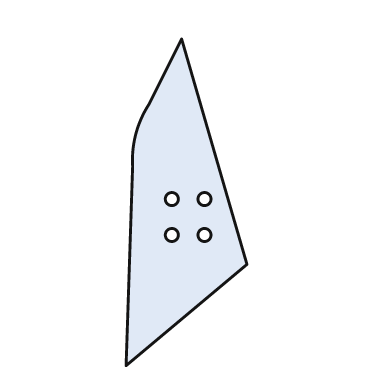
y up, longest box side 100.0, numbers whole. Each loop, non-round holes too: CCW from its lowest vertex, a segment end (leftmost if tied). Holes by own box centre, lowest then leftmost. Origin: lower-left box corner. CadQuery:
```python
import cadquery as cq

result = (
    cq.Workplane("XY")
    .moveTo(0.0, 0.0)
    .lineTo(37.0, 31.0)
    .lineTo(17.0, 100.0)
    .lineTo(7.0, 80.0)
    .threePointArc((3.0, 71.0), (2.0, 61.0))
    .close()
    .moveTo(14.0, 40.0)
    .circle(2.0)
    .moveTo(24.0, 40.0)
    .circle(2.0)
    .moveTo(14.0, 51.0)
    .circle(2.0)
    .moveTo(24.0, 51.0)
    .circle(2.0)
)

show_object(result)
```